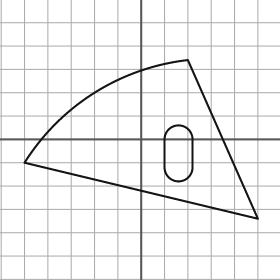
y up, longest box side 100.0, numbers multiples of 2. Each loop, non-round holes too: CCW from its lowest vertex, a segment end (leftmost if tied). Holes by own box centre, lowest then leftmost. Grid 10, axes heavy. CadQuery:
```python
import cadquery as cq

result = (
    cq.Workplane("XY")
    .moveTo(50.0, -34.0)
    .lineTo(20.0, 34.0)
    .threePointArc((-20.0, 20.0), (-50.0, -10.0))
    .close()
    .moveTo(10.0, -12.0)
    .threePointArc((16.0, -18.0), (22.0, -12.0))
    .lineTo(22.0, 0.0)
    .threePointArc((16.0, 6.0), (10.0, 0.0))
    .close()
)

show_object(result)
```